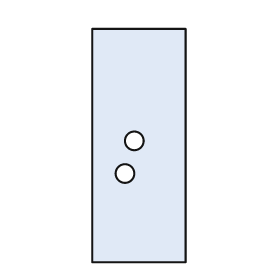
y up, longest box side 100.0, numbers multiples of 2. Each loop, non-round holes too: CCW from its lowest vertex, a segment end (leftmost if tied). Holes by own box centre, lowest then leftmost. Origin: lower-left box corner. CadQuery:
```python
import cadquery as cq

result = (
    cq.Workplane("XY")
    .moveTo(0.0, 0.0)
    .lineTo(40.0, 0.0)
    .lineTo(40.0, 100.0)
    .lineTo(0.0, 100.0)
    .close()
    .moveTo(14.0, 38.0)
    .circle(4.0)
    .moveTo(18.0, 52.0)
    .circle(4.0)
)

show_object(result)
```